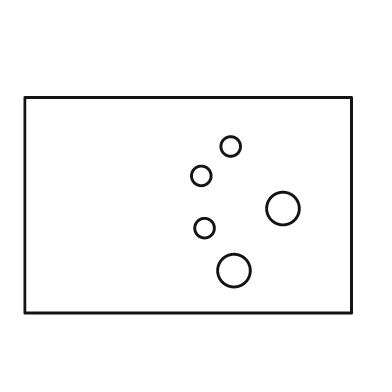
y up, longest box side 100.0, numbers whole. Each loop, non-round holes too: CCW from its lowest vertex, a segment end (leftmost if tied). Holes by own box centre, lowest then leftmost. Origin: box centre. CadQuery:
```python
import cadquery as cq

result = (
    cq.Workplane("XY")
    .moveTo(-50.0, -33.0)
    .lineTo(50.0, -33.0)
    .lineTo(50.0, 33.0)
    .lineTo(-50.0, 33.0)
    .close()
    .moveTo(14.0, -20.0)
    .circle(5.0)
    .moveTo(5.0, -7.0)
    .circle(3.0)
    .moveTo(29.0, -1.0)
    .circle(5.0)
    .moveTo(4.0, 9.0)
    .circle(3.0)
    .moveTo(13.0, 18.0)
    .circle(3.0)
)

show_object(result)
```